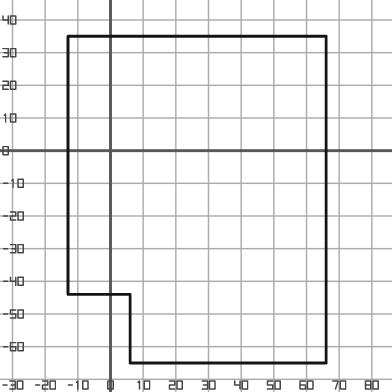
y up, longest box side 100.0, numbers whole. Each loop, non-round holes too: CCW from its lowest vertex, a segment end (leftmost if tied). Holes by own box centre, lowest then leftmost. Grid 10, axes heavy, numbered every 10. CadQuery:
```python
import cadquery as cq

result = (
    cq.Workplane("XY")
    .moveTo(6.0, -65.0)
    .lineTo(66.0, -65.0)
    .lineTo(66.0, 35.0)
    .lineTo(-13.0, 35.0)
    .lineTo(-13.0, -44.0)
    .lineTo(6.0, -44.0)
    .close()
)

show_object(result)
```